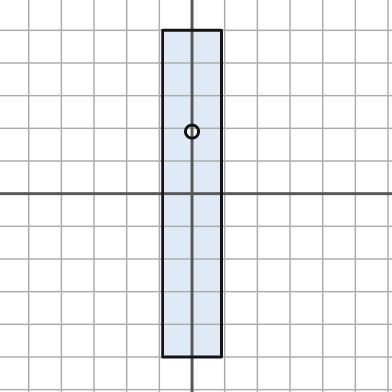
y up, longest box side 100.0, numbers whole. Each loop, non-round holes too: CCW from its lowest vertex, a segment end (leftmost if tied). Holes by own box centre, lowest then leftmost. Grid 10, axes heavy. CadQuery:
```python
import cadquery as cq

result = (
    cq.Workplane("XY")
    .moveTo(-9.0, -50.0)
    .lineTo(9.0, -50.0)
    .lineTo(9.0, 50.0)
    .lineTo(-9.0, 50.0)
    .close()
    .moveTo(0.0, 19.0)
    .circle(2.0)
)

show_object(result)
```